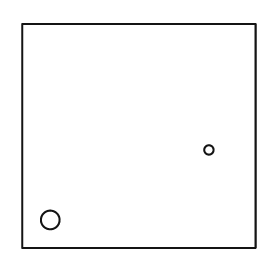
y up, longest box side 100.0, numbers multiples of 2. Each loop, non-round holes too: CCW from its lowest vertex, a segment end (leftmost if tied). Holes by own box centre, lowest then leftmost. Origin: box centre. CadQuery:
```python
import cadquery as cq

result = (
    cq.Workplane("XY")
    .moveTo(-50.0, -48.0)
    .lineTo(50.0, -48.0)
    .lineTo(50.0, 48.0)
    .lineTo(-50.0, 48.0)
    .close()
    .moveTo(-38.0, -36.0)
    .circle(4.0)
    .moveTo(30.0, -6.0)
    .circle(2.0)
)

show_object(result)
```